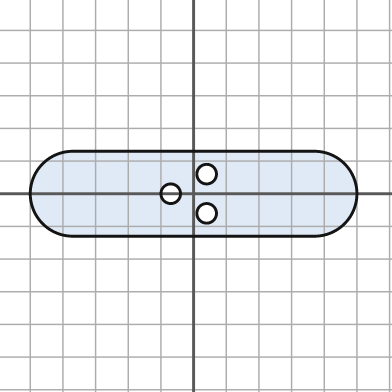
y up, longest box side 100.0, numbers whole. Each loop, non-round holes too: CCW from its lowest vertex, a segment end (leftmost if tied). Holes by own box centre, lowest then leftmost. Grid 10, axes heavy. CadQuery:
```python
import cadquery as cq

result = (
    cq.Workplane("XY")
    .moveTo(-37.0, -13.0)
    .lineTo(37.0, -13.0)
    .threePointArc((50.0, 0.0), (37.0, 13.0))
    .lineTo(-37.0, 13.0)
    .threePointArc((-50.0, 0.0), (-37.0, -13.0))
    .close()
    .moveTo(4.0, -6.0)
    .circle(3.0)
    .moveTo(-7.0, 0.0)
    .circle(3.0)
    .moveTo(4.0, 6.0)
    .circle(3.0)
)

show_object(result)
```